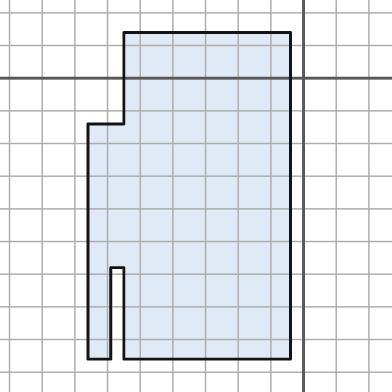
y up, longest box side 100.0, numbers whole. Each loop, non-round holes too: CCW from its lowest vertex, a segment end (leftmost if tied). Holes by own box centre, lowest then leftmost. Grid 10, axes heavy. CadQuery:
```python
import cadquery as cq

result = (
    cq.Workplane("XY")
    .moveTo(-66.0, -86.0)
    .lineTo(-59.0, -86.0)
    .lineTo(-59.0, -58.0)
    .lineTo(-55.0, -58.0)
    .lineTo(-55.0, -86.0)
    .lineTo(-4.0, -86.0)
    .lineTo(-4.0, 14.0)
    .lineTo(-55.0, 14.0)
    .lineTo(-55.0, -14.0)
    .lineTo(-66.0, -14.0)
    .close()
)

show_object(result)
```